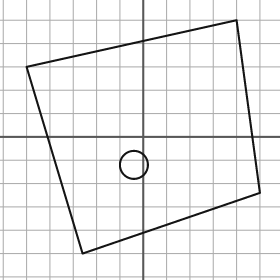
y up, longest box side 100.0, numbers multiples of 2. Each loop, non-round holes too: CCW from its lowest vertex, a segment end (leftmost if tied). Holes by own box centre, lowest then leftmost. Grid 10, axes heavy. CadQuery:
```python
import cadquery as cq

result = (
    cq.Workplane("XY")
    .moveTo(-26.0, -50.0)
    .lineTo(50.0, -24.0)
    .lineTo(40.0, 50.0)
    .lineTo(-50.0, 30.0)
    .close()
    .moveTo(-4.0, -12.0)
    .circle(6.0)
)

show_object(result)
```